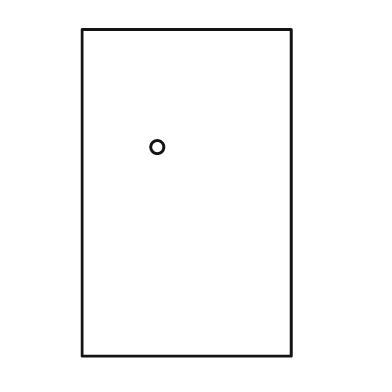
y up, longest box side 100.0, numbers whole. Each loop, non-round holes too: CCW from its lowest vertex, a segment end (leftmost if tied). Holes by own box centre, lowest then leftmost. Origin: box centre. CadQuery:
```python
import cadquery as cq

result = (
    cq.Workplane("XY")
    .moveTo(-32.0, -50.0)
    .lineTo(32.0, -50.0)
    .lineTo(32.0, 50.0)
    .lineTo(-32.0, 50.0)
    .close()
    .moveTo(-9.0, 14.0)
    .circle(2.0)
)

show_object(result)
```